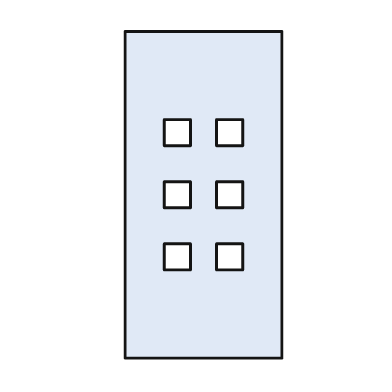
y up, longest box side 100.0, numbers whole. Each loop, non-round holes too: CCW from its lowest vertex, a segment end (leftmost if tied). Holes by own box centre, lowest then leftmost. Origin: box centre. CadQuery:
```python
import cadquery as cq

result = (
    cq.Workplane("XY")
    .moveTo(-24.0, -50.0)
    .lineTo(24.0, -50.0)
    .lineTo(24.0, 50.0)
    .lineTo(-24.0, 50.0)
    .close()
    .moveTo(-12.0, -23.0)
    .lineTo(-4.0, -23.0)
    .lineTo(-4.0, -15.0)
    .lineTo(-12.0, -15.0)
    .close()
    .moveTo(4.0, -23.0)
    .lineTo(12.0, -23.0)
    .lineTo(12.0, -15.0)
    .lineTo(4.0, -15.0)
    .close()
    .moveTo(-12.0, -4.0)
    .lineTo(-4.0, -4.0)
    .lineTo(-4.0, 4.0)
    .lineTo(-12.0, 4.0)
    .close()
    .moveTo(4.0, -4.0)
    .lineTo(12.0, -4.0)
    .lineTo(12.0, 4.0)
    .lineTo(4.0, 4.0)
    .close()
    .moveTo(-12.0, 15.0)
    .lineTo(-4.0, 15.0)
    .lineTo(-4.0, 23.0)
    .lineTo(-12.0, 23.0)
    .close()
    .moveTo(4.0, 15.0)
    .lineTo(12.0, 15.0)
    .lineTo(12.0, 23.0)
    .lineTo(4.0, 23.0)
    .close()
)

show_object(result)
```